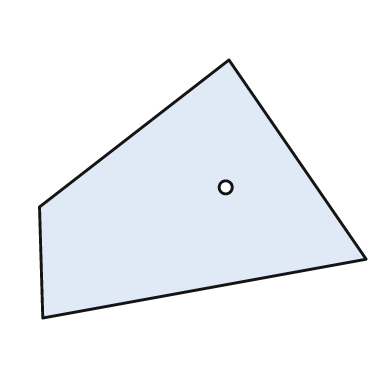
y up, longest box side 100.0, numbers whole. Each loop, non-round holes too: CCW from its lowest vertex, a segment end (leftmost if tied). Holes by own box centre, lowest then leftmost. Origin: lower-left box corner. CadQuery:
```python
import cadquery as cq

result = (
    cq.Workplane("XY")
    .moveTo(1.0, 0.0)
    .lineTo(100.0, 18.0)
    .lineTo(58.0, 79.0)
    .lineTo(0.0, 34.0)
    .close()
    .moveTo(57.0, 40.0)
    .circle(2.0)
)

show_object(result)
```